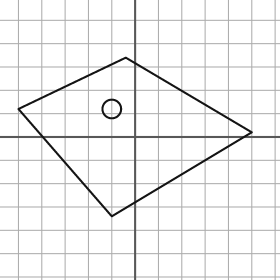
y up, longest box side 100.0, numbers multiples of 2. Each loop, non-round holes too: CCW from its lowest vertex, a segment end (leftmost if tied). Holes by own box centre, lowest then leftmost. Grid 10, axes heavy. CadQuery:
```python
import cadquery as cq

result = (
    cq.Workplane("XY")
    .moveTo(-10.0, -34.0)
    .lineTo(50.0, 2.0)
    .lineTo(-4.0, 34.0)
    .lineTo(-50.0, 12.0)
    .close()
    .moveTo(-10.0, 12.0)
    .circle(4.0)
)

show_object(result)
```